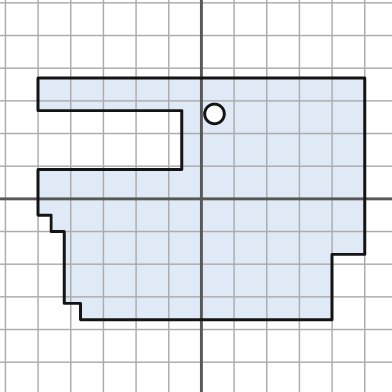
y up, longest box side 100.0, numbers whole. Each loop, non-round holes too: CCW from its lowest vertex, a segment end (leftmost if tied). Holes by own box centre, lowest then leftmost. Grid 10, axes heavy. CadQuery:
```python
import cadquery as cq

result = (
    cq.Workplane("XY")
    .moveTo(-37.0, -37.0)
    .lineTo(40.0, -37.0)
    .lineTo(40.0, -17.0)
    .lineTo(50.0, -17.0)
    .lineTo(50.0, 37.0)
    .lineTo(-50.0, 37.0)
    .lineTo(-50.0, 27.0)
    .lineTo(-6.0, 27.0)
    .lineTo(-6.0, 9.0)
    .lineTo(-50.0, 9.0)
    .lineTo(-50.0, -5.0)
    .lineTo(-46.0, -5.0)
    .lineTo(-46.0, -10.0)
    .lineTo(-42.0, -10.0)
    .lineTo(-42.0, -32.0)
    .lineTo(-37.0, -32.0)
    .close()
    .moveTo(4.0, 26.0)
    .circle(3.0)
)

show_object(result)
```